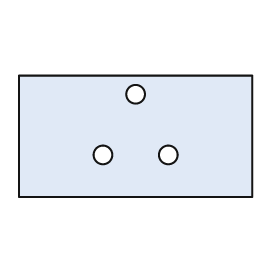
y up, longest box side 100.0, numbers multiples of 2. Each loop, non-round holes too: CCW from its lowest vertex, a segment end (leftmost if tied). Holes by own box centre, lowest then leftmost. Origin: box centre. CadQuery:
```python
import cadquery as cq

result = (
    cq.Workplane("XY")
    .moveTo(-50.0, -26.0)
    .lineTo(50.0, -26.0)
    .lineTo(50.0, 26.0)
    .lineTo(-50.0, 26.0)
    .close()
    .moveTo(-14.0, -8.0)
    .circle(4.0)
    .moveTo(14.0, -8.0)
    .circle(4.0)
    .moveTo(0.0, 18.0)
    .circle(4.0)
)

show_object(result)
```